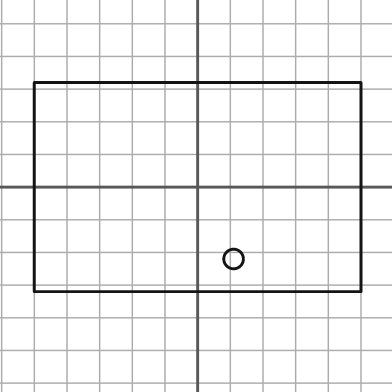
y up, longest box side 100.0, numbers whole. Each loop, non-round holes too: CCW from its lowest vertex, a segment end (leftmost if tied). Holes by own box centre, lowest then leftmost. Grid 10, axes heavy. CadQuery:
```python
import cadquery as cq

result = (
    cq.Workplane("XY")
    .moveTo(-50.0, -32.0)
    .lineTo(50.0, -32.0)
    .lineTo(50.0, 32.0)
    .lineTo(-50.0, 32.0)
    .close()
    .moveTo(11.0, -22.0)
    .circle(3.0)
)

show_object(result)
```